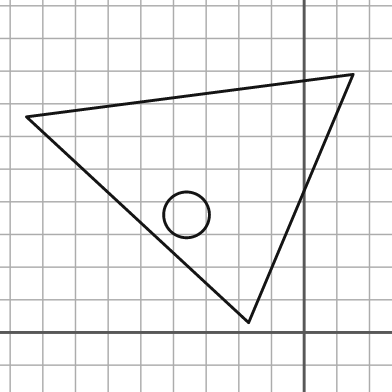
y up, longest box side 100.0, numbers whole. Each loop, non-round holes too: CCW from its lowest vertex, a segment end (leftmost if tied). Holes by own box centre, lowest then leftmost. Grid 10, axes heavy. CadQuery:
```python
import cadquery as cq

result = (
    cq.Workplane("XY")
    .moveTo(-17.0, 3.0)
    .lineTo(15.0, 79.0)
    .lineTo(-85.0, 66.0)
    .close()
    .moveTo(-36.0, 36.0)
    .circle(7.0)
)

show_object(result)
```